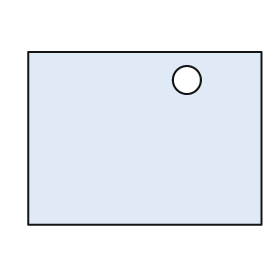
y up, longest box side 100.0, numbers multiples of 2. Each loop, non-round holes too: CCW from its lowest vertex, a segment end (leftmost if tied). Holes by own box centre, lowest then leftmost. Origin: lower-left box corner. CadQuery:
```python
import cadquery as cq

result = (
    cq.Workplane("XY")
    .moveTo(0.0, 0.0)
    .lineTo(100.0, 0.0)
    .lineTo(100.0, 74.0)
    .lineTo(0.0, 74.0)
    .close()
    .moveTo(68.0, 62.0)
    .circle(6.0)
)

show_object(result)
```